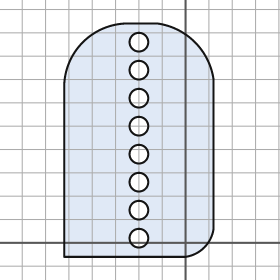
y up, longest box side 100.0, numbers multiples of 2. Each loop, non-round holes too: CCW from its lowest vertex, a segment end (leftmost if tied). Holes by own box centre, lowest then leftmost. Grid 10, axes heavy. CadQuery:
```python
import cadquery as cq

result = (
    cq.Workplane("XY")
    .moveTo(-52.0, -6.0)
    .lineTo(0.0, -6.0)
    .threePointArc((8.0, -2.0), (12.0, 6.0))
    .lineTo(12.0, 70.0)
    .threePointArc((4.0, 86.0), (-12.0, 94.0))
    .lineTo(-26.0, 94.0)
    .threePointArc((-44.0, 86.0), (-52.0, 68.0))
    .close()
    .moveTo(-20.0, 2.0)
    .circle(4.0)
    .moveTo(-20.0, 14.0)
    .circle(4.0)
    .moveTo(-20.0, 26.0)
    .circle(4.0)
    .moveTo(-20.0, 38.0)
    .circle(4.0)
    .moveTo(-20.0, 50.0)
    .circle(4.0)
    .moveTo(-20.0, 62.0)
    .circle(4.0)
    .moveTo(-20.0, 74.0)
    .circle(4.0)
    .moveTo(-20.0, 86.0)
    .circle(4.0)
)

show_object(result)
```